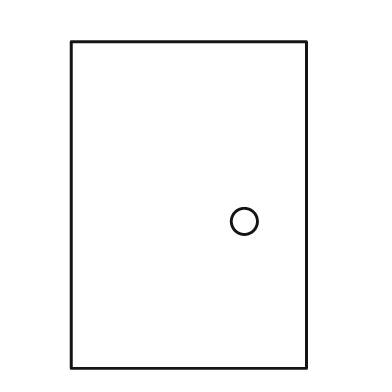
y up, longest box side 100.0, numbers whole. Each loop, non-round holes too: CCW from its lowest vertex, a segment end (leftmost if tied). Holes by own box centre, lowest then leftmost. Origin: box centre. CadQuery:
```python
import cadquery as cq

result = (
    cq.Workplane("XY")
    .moveTo(-36.0, -50.0)
    .lineTo(36.0, -50.0)
    .lineTo(36.0, 50.0)
    .lineTo(-36.0, 50.0)
    .close()
    .moveTo(17.0, -5.0)
    .circle(4.0)
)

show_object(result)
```